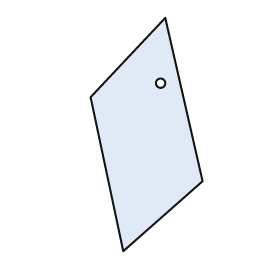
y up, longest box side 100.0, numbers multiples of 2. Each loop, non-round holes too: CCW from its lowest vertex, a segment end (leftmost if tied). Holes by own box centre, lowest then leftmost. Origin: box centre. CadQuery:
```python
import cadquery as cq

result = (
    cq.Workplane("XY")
    .moveTo(-10.0, -50.0)
    .lineTo(24.0, -20.0)
    .lineTo(8.0, 50.0)
    .lineTo(-24.0, 16.0)
    .close()
    .moveTo(6.0, 22.0)
    .circle(2.0)
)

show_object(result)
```